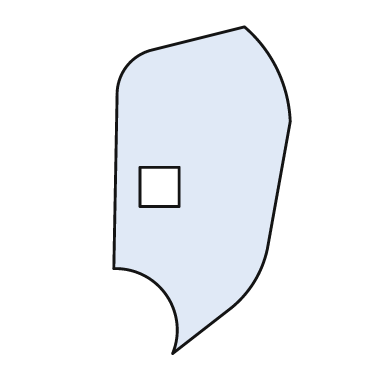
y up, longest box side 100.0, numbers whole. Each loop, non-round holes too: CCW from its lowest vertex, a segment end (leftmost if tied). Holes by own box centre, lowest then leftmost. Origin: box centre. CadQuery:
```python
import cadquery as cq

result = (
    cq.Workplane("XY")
    .moveTo(-9.0, -50.0)
    .lineTo(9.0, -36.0)
    .threePointArc((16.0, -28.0), (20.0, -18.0))
    .lineTo(27.0, 21.0)
    .threePointArc((23.0, 37.0), (13.0, 50.0))
    .lineTo(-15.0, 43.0)
    .threePointArc((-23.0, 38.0), (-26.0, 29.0))
    .lineTo(-27.0, -24.0)
    .threePointArc((-11.0, -32.0), (-9.0, -50.0))
    .close()
    .moveTo(-19.0, -5.0)
    .lineTo(-7.0, -5.0)
    .lineTo(-7.0, 7.0)
    .lineTo(-19.0, 7.0)
    .close()
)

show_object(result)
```